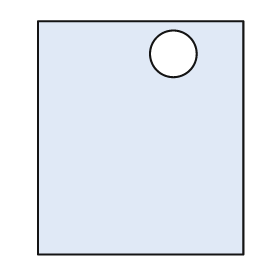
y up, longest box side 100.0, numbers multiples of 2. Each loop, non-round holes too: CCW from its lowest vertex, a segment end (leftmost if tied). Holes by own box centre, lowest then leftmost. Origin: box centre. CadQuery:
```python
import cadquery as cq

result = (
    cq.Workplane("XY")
    .moveTo(-44.0, -50.0)
    .lineTo(44.0, -50.0)
    .lineTo(44.0, 50.0)
    .lineTo(-44.0, 50.0)
    .close()
    .moveTo(14.0, 36.0)
    .circle(10.0)
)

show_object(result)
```